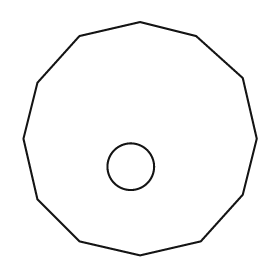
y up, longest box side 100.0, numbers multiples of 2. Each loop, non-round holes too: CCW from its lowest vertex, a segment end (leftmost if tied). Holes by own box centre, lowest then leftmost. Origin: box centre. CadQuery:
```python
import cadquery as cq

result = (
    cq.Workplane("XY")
    .moveTo(0.0, -50.0)
    .lineTo(26.0, -44.0)
    .lineTo(44.0, -24.0)
    .lineTo(50.0, 0.0)
    .lineTo(44.0, 26.0)
    .lineTo(24.0, 44.0)
    .lineTo(0.0, 50.0)
    .lineTo(-26.0, 44.0)
    .lineTo(-44.0, 24.0)
    .lineTo(-50.0, 0.0)
    .lineTo(-44.0, -26.0)
    .lineTo(-26.0, -44.0)
    .close()
    .moveTo(-4.0, -12.0)
    .circle(10.0)
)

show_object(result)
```